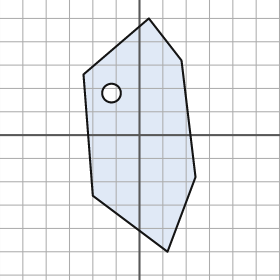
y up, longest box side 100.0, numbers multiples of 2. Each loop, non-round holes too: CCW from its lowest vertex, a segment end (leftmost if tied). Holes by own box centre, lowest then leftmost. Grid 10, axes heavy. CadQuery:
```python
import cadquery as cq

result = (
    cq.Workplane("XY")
    .moveTo(12.0, -50.0)
    .lineTo(24.0, -18.0)
    .lineTo(18.0, 32.0)
    .lineTo(4.0, 50.0)
    .lineTo(-24.0, 26.0)
    .lineTo(-20.0, -26.0)
    .close()
    .moveTo(-12.0, 18.0)
    .circle(4.0)
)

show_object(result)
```